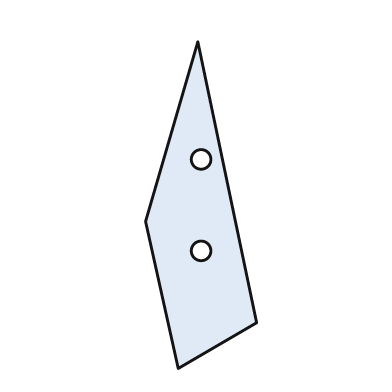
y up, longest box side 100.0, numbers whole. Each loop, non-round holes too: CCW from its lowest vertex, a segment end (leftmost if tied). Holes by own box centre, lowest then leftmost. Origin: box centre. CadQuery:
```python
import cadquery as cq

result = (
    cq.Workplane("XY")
    .moveTo(-7.0, -50.0)
    .lineTo(17.0, -36.0)
    .lineTo(-1.0, 50.0)
    .lineTo(-17.0, -5.0)
    .close()
    .moveTo(0.0, -14.0)
    .circle(3.0)
    .moveTo(0.0, 14.0)
    .circle(3.0)
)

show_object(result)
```